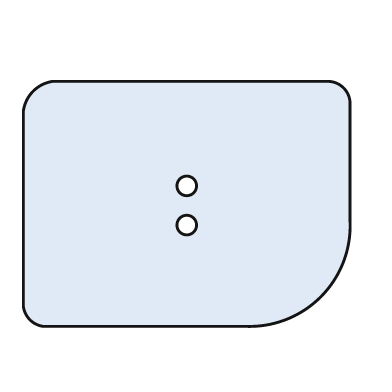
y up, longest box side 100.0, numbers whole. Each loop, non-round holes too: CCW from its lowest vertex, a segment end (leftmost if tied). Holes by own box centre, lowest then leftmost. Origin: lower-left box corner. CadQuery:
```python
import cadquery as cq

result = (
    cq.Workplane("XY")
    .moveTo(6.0, 0.0)
    .lineTo(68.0, 0.0)
    .threePointArc((91.0, 9.0), (100.0, 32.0))
    .lineTo(100.0, 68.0)
    .threePointArc((98.0, 73.0), (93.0, 75.0))
    .lineTo(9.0, 75.0)
    .threePointArc((3.0, 72.0), (0.0, 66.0))
    .lineTo(0.0, 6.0)
    .threePointArc((2.0, 2.0), (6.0, 0.0))
    .close()
    .moveTo(50.0, 31.0)
    .circle(3.0)
    .moveTo(50.0, 43.0)
    .circle(3.0)
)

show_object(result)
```